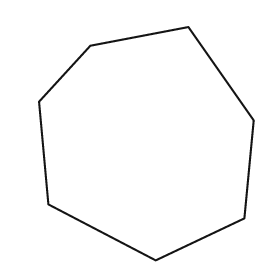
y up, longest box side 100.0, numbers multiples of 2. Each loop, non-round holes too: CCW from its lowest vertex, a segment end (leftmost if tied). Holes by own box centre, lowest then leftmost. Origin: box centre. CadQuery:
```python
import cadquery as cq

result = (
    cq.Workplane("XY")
    .moveTo(4.0, -50.0)
    .lineTo(42.0, -32.0)
    .lineTo(46.0, 10.0)
    .lineTo(18.0, 50.0)
    .lineTo(-24.0, 42.0)
    .lineTo(-46.0, 18.0)
    .lineTo(-42.0, -26.0)
    .close()
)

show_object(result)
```